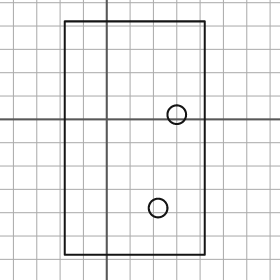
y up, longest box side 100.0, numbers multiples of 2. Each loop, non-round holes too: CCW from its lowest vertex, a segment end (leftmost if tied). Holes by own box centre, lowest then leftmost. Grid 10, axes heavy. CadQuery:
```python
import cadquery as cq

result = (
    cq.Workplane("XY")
    .moveTo(-18.0, -58.0)
    .lineTo(42.0, -58.0)
    .lineTo(42.0, 42.0)
    .lineTo(-18.0, 42.0)
    .close()
    .moveTo(22.0, -38.0)
    .circle(4.0)
    .moveTo(30.0, 2.0)
    .circle(4.0)
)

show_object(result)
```